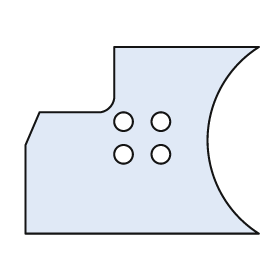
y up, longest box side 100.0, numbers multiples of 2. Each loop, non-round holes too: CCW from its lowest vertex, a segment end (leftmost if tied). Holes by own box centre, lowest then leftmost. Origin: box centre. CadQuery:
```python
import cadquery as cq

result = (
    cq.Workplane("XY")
    .moveTo(-50.0, -40.0)
    .lineTo(50.0, -40.0)
    .threePointArc((28.0, 0.0), (50.0, 40.0))
    .lineTo(-12.0, 40.0)
    .lineTo(-12.0, 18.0)
    .threePointArc((-14.0, 14.0), (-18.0, 12.0))
    .lineTo(-44.0, 12.0)
    .lineTo(-50.0, -2.0)
    .close()
    .moveTo(-8.0, -6.0)
    .circle(4.0)
    .moveTo(8.0, -6.0)
    .circle(4.0)
    .moveTo(-8.0, 8.0)
    .circle(4.0)
    .moveTo(8.0, 8.0)
    .circle(4.0)
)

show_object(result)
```